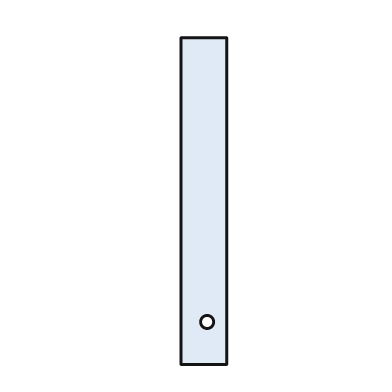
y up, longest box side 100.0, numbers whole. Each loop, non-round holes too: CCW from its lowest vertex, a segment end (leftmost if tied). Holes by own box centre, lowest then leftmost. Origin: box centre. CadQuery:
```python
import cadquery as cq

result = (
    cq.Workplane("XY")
    .moveTo(-7.0, -50.0)
    .lineTo(7.0, -50.0)
    .lineTo(7.0, 50.0)
    .lineTo(-7.0, 50.0)
    .close()
    .moveTo(1.0, -37.0)
    .circle(2.0)
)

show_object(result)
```